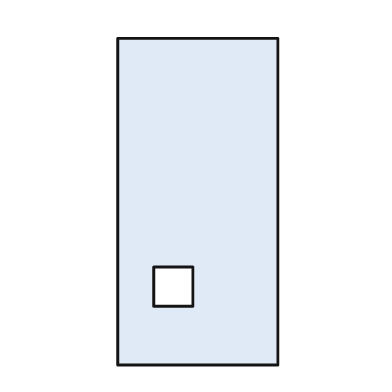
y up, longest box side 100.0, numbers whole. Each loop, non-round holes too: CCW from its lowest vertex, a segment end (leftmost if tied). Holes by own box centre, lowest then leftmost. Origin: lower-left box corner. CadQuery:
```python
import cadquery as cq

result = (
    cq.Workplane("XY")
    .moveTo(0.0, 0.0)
    .lineTo(49.0, 0.0)
    .lineTo(49.0, 100.0)
    .lineTo(0.0, 100.0)
    .close()
    .moveTo(11.0, 18.0)
    .lineTo(23.0, 18.0)
    .lineTo(23.0, 30.0)
    .lineTo(11.0, 30.0)
    .close()
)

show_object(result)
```